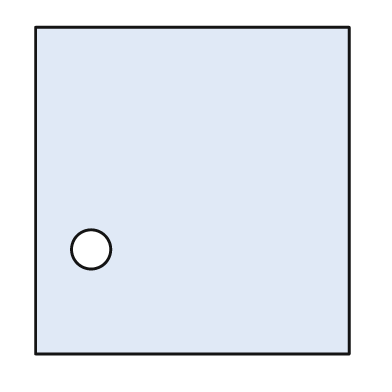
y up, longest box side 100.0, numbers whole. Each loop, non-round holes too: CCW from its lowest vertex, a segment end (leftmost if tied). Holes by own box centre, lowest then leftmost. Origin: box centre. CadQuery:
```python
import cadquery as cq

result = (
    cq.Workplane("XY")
    .moveTo(-48.0, -50.0)
    .lineTo(48.0, -50.0)
    .lineTo(48.0, 50.0)
    .lineTo(-48.0, 50.0)
    .close()
    .moveTo(-31.0, -18.0)
    .circle(6.0)
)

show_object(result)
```